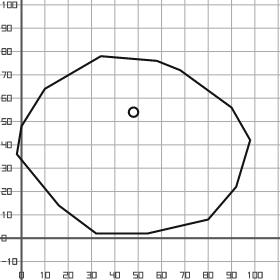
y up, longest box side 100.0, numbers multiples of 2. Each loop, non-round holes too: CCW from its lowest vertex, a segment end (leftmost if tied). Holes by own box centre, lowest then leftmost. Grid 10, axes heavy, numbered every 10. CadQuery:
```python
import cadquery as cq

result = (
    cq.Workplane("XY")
    .moveTo(32.0, 2.0)
    .lineTo(54.0, 2.0)
    .lineTo(80.0, 8.0)
    .lineTo(92.0, 22.0)
    .lineTo(98.0, 42.0)
    .lineTo(90.0, 56.0)
    .lineTo(68.0, 72.0)
    .lineTo(58.0, 76.0)
    .lineTo(34.0, 78.0)
    .lineTo(10.0, 64.0)
    .lineTo(0.0, 48.0)
    .lineTo(-2.0, 36.0)
    .lineTo(16.0, 14.0)
    .close()
    .moveTo(48.0, 54.0)
    .circle(2.0)
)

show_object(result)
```